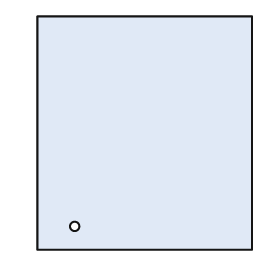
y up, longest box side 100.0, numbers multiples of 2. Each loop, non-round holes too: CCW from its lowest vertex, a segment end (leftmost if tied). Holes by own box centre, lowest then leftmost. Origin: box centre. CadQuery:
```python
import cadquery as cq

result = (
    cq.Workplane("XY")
    .moveTo(-46.0, -50.0)
    .lineTo(46.0, -50.0)
    .lineTo(46.0, 50.0)
    .lineTo(-46.0, 50.0)
    .close()
    .moveTo(-30.0, -40.0)
    .circle(2.0)
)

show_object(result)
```